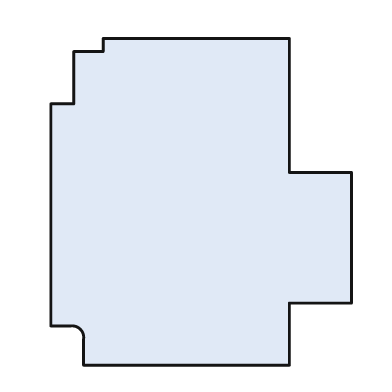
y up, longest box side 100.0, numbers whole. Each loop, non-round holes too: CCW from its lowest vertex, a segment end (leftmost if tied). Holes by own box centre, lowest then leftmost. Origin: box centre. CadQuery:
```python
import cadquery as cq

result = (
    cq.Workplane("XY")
    .moveTo(-36.0, -50.0)
    .lineTo(27.0, -50.0)
    .lineTo(27.0, -31.0)
    .lineTo(46.0, -31.0)
    .lineTo(46.0, 9.0)
    .lineTo(27.0, 9.0)
    .lineTo(27.0, 50.0)
    .lineTo(-30.0, 50.0)
    .lineTo(-30.0, 46.0)
    .lineTo(-39.0, 46.0)
    .lineTo(-39.0, 30.0)
    .lineTo(-46.0, 30.0)
    .lineTo(-46.0, -38.0)
    .lineTo(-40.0, -38.0)
    .threePointArc((-37.0, -39.0), (-36.0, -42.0))
    .close()
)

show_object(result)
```